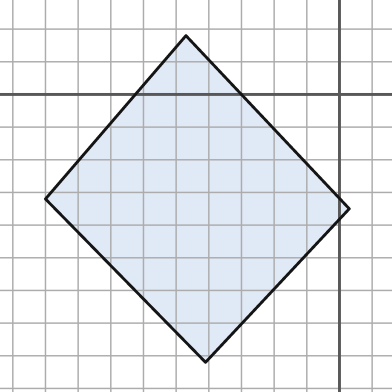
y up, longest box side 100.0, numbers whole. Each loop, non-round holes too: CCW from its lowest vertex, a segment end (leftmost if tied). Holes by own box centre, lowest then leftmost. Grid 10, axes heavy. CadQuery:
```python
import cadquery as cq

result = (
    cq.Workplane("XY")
    .moveTo(-41.0, -82.0)
    .lineTo(3.0, -35.0)
    .lineTo(-47.0, 18.0)
    .lineTo(-90.0, -32.0)
    .close()
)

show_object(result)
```